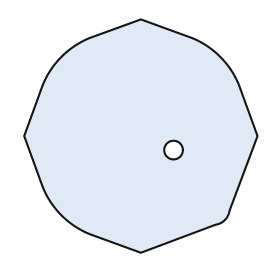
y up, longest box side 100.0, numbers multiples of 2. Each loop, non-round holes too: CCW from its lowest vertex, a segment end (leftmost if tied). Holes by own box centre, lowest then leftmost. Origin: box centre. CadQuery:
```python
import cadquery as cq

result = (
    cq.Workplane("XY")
    .moveTo(0.0, -50.0)
    .lineTo(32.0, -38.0)
    .threePointArc((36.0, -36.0), (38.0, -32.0))
    .lineTo(50.0, 0.0)
    .lineTo(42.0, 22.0)
    .threePointArc((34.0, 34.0), (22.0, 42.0))
    .lineTo(0.0, 50.0)
    .lineTo(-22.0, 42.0)
    .threePointArc((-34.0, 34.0), (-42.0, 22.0))
    .lineTo(-50.0, 0.0)
    .lineTo(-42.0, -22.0)
    .threePointArc((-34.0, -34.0), (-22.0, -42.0))
    .close()
    .moveTo(14.0, -6.0)
    .circle(4.0)
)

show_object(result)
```